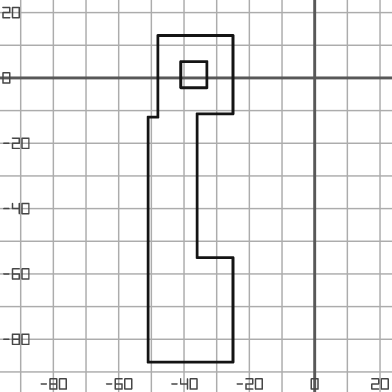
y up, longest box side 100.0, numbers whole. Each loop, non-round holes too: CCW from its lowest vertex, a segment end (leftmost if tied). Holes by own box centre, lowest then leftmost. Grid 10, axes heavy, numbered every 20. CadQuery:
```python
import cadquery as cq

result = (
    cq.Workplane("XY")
    .moveTo(-51.0, -87.0)
    .lineTo(-25.0, -87.0)
    .lineTo(-25.0, -55.0)
    .lineTo(-36.0, -55.0)
    .lineTo(-36.0, -11.0)
    .lineTo(-25.0, -11.0)
    .lineTo(-25.0, 13.0)
    .lineTo(-48.0, 13.0)
    .lineTo(-48.0, -12.0)
    .lineTo(-51.0, -12.0)
    .close()
    .moveTo(-41.0, -3.0)
    .lineTo(-33.0, -3.0)
    .lineTo(-33.0, 5.0)
    .lineTo(-41.0, 5.0)
    .close()
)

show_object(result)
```